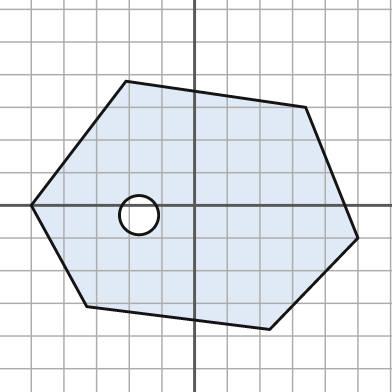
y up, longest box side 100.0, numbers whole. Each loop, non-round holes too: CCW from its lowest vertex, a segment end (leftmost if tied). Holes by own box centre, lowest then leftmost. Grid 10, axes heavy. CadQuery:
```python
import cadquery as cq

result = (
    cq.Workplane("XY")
    .moveTo(23.0, -38.0)
    .lineTo(50.0, -10.0)
    .lineTo(34.0, 30.0)
    .lineTo(-21.0, 38.0)
    .lineTo(-50.0, 0.0)
    .lineTo(-33.0, -31.0)
    .close()
    .moveTo(-17.0, -3.0)
    .circle(6.0)
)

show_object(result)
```